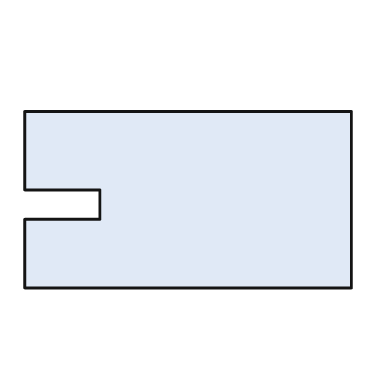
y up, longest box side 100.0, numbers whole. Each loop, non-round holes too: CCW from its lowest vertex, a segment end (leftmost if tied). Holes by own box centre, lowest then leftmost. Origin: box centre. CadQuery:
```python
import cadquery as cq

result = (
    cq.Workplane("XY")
    .moveTo(-50.0, -27.0)
    .lineTo(50.0, -27.0)
    .lineTo(50.0, 27.0)
    .lineTo(-50.0, 27.0)
    .lineTo(-50.0, 3.0)
    .lineTo(-27.0, 3.0)
    .lineTo(-27.0, -6.0)
    .lineTo(-50.0, -6.0)
    .close()
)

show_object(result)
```